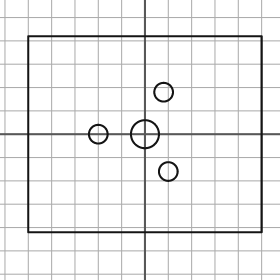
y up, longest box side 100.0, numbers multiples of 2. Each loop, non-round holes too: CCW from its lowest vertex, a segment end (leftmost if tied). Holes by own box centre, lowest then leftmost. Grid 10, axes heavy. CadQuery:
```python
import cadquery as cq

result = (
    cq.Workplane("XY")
    .moveTo(-50.0, -42.0)
    .lineTo(50.0, -42.0)
    .lineTo(50.0, 42.0)
    .lineTo(-50.0, 42.0)
    .close()
    .moveTo(10.0, -16.0)
    .circle(4.0)
    .moveTo(-20.0, 0.0)
    .circle(4.0)
    .moveTo(0.0, 0.0)
    .circle(6.0)
    .moveTo(8.0, 18.0)
    .circle(4.0)
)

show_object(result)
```